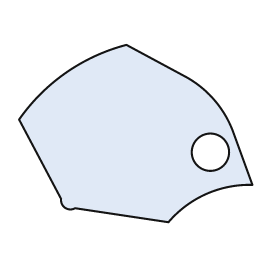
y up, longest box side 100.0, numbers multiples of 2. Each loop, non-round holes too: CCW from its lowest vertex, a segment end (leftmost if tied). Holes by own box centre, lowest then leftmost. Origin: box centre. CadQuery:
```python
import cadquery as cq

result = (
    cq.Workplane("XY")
    .moveTo(14.0, -38.0)
    .threePointArc((30.0, -26.0), (50.0, -22.0))
    .lineTo(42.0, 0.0)
    .threePointArc((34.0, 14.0), (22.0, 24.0))
    .lineTo(-4.0, 38.0)
    .threePointArc((-30.0, 26.0), (-50.0, 6.0))
    .lineTo(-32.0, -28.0)
    .threePointArc((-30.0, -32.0), (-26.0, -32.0))
    .close()
    .moveTo(32.0, -8.0)
    .circle(8.0)
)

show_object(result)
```